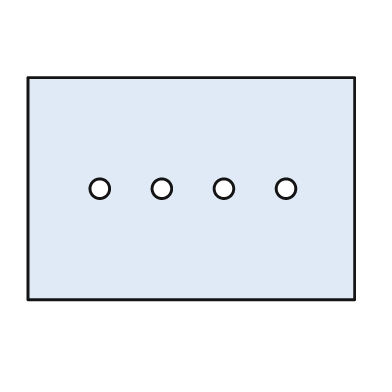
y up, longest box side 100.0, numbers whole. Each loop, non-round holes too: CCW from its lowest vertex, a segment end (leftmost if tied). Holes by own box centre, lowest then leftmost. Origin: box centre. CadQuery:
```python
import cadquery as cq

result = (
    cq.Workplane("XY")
    .moveTo(-50.0, -34.0)
    .lineTo(50.0, -34.0)
    .lineTo(50.0, 34.0)
    .lineTo(-50.0, 34.0)
    .close()
    .moveTo(-28.0, 0.0)
    .circle(3.0)
    .moveTo(-9.0, 0.0)
    .circle(3.0)
    .moveTo(10.0, 0.0)
    .circle(3.0)
    .moveTo(29.0, 0.0)
    .circle(3.0)
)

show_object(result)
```